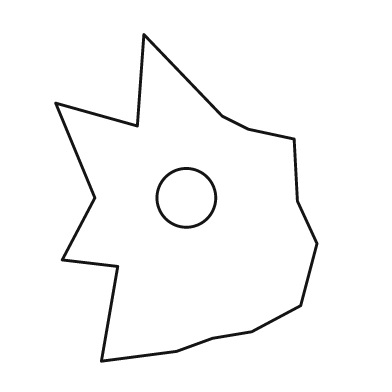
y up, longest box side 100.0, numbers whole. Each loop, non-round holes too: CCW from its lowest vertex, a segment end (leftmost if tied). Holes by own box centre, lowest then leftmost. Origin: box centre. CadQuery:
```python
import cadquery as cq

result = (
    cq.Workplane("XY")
    .moveTo(-26.0, -50.0)
    .lineTo(-3.0, -47.0)
    .lineTo(8.0, -43.0)
    .lineTo(20.0, -41.0)
    .lineTo(35.0, -33.0)
    .lineTo(40.0, -14.0)
    .lineTo(34.0, -1.0)
    .lineTo(33.0, 18.0)
    .lineTo(19.0, 21.0)
    .lineTo(11.0, 25.0)
    .lineTo(-13.0, 50.0)
    .lineTo(-15.0, 22.0)
    .lineTo(-40.0, 29.0)
    .lineTo(-28.0, 0.0)
    .lineTo(-38.0, -19.0)
    .lineTo(-21.0, -21.0)
    .close()
    .moveTo(0.0, 0.0)
    .circle(9.0)
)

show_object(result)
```